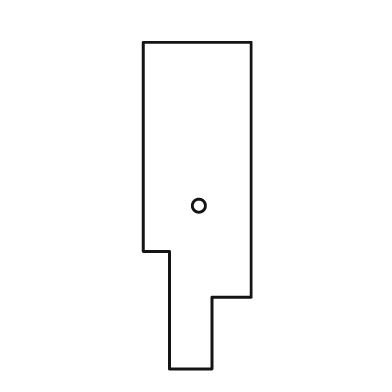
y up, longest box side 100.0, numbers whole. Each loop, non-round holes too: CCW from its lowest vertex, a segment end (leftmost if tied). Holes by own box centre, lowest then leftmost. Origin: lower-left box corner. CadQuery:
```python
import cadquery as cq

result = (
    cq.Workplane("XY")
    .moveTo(8.0, 0.0)
    .lineTo(21.0, 0.0)
    .lineTo(21.0, 22.0)
    .lineTo(33.0, 22.0)
    .lineTo(33.0, 100.0)
    .lineTo(0.0, 100.0)
    .lineTo(0.0, 36.0)
    .lineTo(8.0, 36.0)
    .close()
    .moveTo(17.0, 50.0)
    .circle(2.0)
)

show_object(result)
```